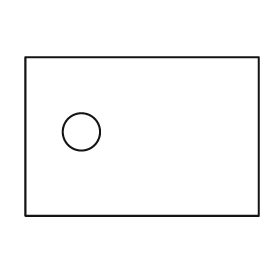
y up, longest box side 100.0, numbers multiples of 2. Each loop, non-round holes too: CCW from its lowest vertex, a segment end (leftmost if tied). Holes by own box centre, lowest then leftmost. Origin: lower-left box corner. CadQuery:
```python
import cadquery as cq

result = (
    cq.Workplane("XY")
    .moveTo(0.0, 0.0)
    .lineTo(100.0, 0.0)
    .lineTo(100.0, 68.0)
    .lineTo(0.0, 68.0)
    .close()
    .moveTo(24.0, 36.0)
    .circle(8.0)
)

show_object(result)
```